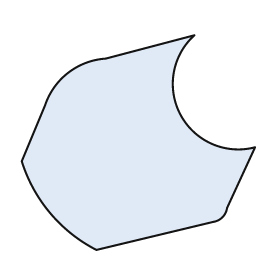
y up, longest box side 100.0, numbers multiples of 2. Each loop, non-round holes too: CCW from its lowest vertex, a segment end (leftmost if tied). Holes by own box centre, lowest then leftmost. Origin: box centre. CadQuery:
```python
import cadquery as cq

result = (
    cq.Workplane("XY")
    .moveTo(-18.0, -46.0)
    .lineTo(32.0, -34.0)
    .threePointArc((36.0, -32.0), (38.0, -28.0))
    .lineTo(50.0, -2.0)
    .threePointArc((18.0, 12.0), (24.0, 46.0))
    .lineTo(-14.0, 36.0)
    .threePointArc((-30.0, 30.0), (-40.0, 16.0))
    .lineTo(-50.0, -8.0)
    .threePointArc((-38.0, -30.0), (-18.0, -46.0))
    .close()
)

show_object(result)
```